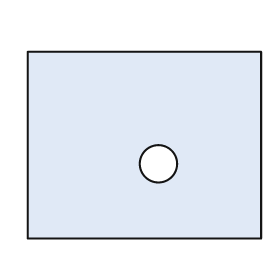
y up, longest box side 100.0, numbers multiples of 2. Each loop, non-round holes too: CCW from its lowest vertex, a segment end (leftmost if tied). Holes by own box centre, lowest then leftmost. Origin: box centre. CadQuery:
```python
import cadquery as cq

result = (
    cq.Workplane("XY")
    .moveTo(-50.0, -40.0)
    .lineTo(50.0, -40.0)
    .lineTo(50.0, 40.0)
    .lineTo(-50.0, 40.0)
    .close()
    .moveTo(6.0, -8.0)
    .circle(8.0)
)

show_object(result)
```